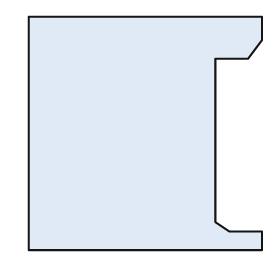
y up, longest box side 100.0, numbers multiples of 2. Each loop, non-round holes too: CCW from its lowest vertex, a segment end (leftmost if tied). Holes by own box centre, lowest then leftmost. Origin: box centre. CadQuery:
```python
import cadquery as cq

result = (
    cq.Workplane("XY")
    .moveTo(-50.0, -50.0)
    .lineTo(50.0, -50.0)
    .lineTo(50.0, -42.0)
    .lineTo(36.0, -42.0)
    .lineTo(30.0, -38.0)
    .lineTo(30.0, 32.0)
    .lineTo(44.0, 32.0)
    .lineTo(50.0, 40.0)
    .lineTo(50.0, 50.0)
    .lineTo(-50.0, 50.0)
    .close()
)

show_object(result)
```